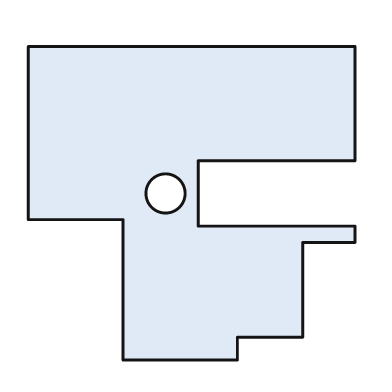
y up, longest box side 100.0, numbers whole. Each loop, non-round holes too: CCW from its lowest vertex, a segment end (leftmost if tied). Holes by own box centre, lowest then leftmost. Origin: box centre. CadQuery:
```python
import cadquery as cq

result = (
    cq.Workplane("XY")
    .moveTo(-21.0, -48.0)
    .lineTo(14.0, -48.0)
    .lineTo(14.0, -41.0)
    .lineTo(34.0, -41.0)
    .lineTo(34.0, -12.0)
    .lineTo(50.0, -12.0)
    .lineTo(50.0, -7.0)
    .lineTo(2.0, -7.0)
    .lineTo(2.0, 13.0)
    .lineTo(50.0, 13.0)
    .lineTo(50.0, 48.0)
    .lineTo(-50.0, 48.0)
    .lineTo(-50.0, -5.0)
    .lineTo(-21.0, -5.0)
    .close()
    .moveTo(-8.0, 3.0)
    .circle(6.0)
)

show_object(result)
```